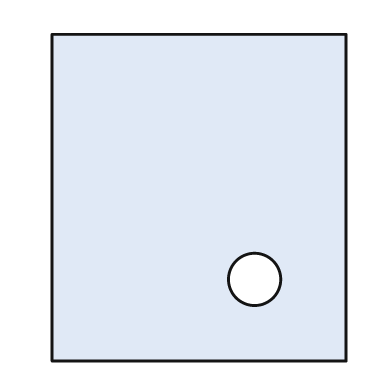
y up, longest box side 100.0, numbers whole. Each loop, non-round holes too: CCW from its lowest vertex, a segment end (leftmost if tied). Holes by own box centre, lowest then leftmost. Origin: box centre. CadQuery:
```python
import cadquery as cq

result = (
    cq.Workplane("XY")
    .moveTo(-45.0, -50.0)
    .lineTo(45.0, -50.0)
    .lineTo(45.0, 50.0)
    .lineTo(-45.0, 50.0)
    .close()
    .moveTo(17.0, -25.0)
    .circle(8.0)
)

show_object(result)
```